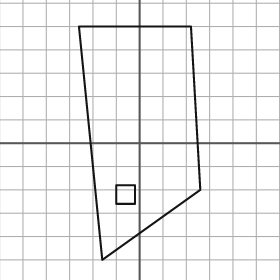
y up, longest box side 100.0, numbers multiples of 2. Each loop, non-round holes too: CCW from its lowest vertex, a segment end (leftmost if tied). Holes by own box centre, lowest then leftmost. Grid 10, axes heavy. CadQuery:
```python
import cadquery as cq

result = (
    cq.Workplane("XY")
    .moveTo(-16.0, -50.0)
    .lineTo(26.0, -20.0)
    .lineTo(22.0, 50.0)
    .lineTo(-26.0, 50.0)
    .close()
    .moveTo(-10.0, -26.0)
    .lineTo(-2.0, -26.0)
    .lineTo(-2.0, -18.0)
    .lineTo(-10.0, -18.0)
    .close()
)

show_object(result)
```